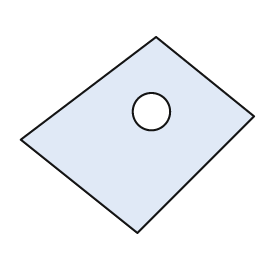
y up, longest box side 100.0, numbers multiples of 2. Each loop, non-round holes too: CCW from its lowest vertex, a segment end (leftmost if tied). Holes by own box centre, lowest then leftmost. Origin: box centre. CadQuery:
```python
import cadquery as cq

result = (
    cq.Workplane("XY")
    .moveTo(0.0, -42.0)
    .lineTo(50.0, 8.0)
    .lineTo(8.0, 42.0)
    .lineTo(-50.0, -2.0)
    .close()
    .moveTo(6.0, 10.0)
    .circle(8.0)
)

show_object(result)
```